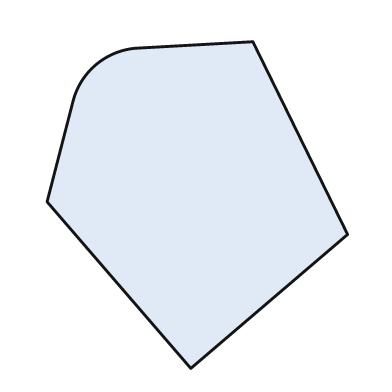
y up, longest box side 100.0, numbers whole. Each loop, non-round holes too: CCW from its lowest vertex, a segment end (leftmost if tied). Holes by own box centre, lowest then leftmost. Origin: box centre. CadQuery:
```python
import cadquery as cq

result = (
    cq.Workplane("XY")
    .moveTo(-2.0, -50.0)
    .lineTo(46.0, -9.0)
    .lineTo(17.0, 50.0)
    .lineTo(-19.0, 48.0)
    .threePointArc((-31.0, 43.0), (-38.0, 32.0))
    .lineTo(-46.0, 1.0)
    .close()
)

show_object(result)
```